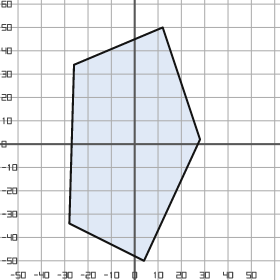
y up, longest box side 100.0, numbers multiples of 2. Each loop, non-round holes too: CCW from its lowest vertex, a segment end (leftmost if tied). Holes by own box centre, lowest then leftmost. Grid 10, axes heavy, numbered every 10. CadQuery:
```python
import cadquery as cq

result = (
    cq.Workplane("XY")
    .moveTo(4.0, -50.0)
    .lineTo(28.0, 2.0)
    .lineTo(12.0, 50.0)
    .lineTo(-26.0, 34.0)
    .lineTo(-28.0, -34.0)
    .close()
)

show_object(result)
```